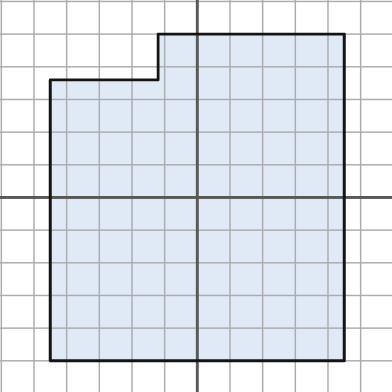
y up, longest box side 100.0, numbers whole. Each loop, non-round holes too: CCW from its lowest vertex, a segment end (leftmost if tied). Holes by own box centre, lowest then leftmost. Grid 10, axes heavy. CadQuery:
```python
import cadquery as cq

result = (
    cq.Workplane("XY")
    .moveTo(-45.0, -50.0)
    .lineTo(45.0, -50.0)
    .lineTo(45.0, 50.0)
    .lineTo(-12.0, 50.0)
    .lineTo(-12.0, 36.0)
    .lineTo(-45.0, 36.0)
    .close()
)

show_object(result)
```